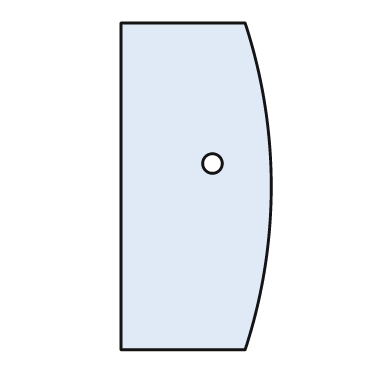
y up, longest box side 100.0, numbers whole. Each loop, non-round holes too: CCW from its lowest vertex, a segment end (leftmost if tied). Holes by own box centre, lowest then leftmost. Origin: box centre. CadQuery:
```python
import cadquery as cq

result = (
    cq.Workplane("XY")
    .moveTo(-23.0, -50.0)
    .lineTo(15.0, -50.0)
    .threePointArc((23.0, 0.0), (15.0, 50.0))
    .lineTo(-23.0, 50.0)
    .close()
    .moveTo(5.0, 7.0)
    .circle(3.0)
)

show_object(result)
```